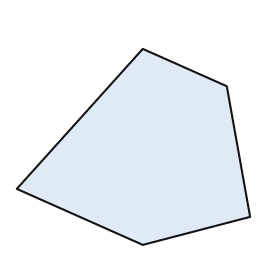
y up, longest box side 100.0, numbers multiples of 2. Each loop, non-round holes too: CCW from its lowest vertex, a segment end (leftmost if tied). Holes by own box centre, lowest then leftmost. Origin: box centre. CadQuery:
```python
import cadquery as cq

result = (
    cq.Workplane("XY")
    .moveTo(4.0, -42.0)
    .lineTo(50.0, -30.0)
    .lineTo(40.0, 26.0)
    .lineTo(4.0, 42.0)
    .lineTo(-50.0, -18.0)
    .close()
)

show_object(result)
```